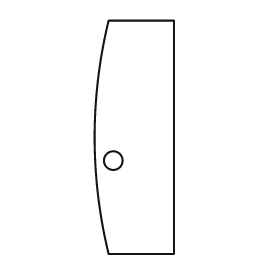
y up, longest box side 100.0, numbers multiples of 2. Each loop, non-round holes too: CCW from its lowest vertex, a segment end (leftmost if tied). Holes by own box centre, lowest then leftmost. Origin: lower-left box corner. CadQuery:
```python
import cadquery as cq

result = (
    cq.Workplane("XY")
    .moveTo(6.0, 0.0)
    .lineTo(34.0, 0.0)
    .lineTo(34.0, 100.0)
    .lineTo(6.0, 100.0)
    .threePointArc((0.0, 50.0), (6.0, 0.0))
    .close()
    .moveTo(8.0, 40.0)
    .circle(4.0)
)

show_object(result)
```